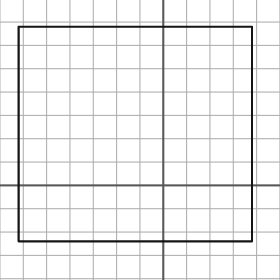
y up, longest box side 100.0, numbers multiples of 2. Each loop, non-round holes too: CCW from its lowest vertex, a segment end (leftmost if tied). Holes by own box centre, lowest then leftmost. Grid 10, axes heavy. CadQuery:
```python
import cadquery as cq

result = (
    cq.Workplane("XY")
    .moveTo(-62.0, -24.0)
    .lineTo(38.0, -24.0)
    .lineTo(38.0, 68.0)
    .lineTo(-62.0, 68.0)
    .close()
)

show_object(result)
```